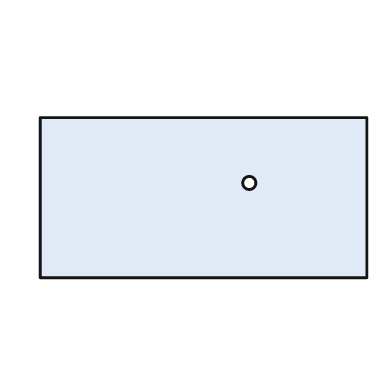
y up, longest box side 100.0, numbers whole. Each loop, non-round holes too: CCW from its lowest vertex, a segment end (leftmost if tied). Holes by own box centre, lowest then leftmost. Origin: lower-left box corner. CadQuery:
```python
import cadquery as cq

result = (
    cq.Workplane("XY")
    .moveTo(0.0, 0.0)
    .lineTo(100.0, 0.0)
    .lineTo(100.0, 49.0)
    .lineTo(0.0, 49.0)
    .close()
    .moveTo(64.0, 29.0)
    .circle(2.0)
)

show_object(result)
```